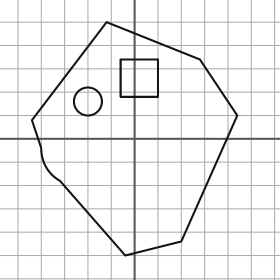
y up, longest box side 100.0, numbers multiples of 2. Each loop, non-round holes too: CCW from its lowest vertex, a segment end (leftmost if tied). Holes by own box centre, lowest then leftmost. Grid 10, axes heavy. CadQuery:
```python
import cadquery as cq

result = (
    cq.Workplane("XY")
    .moveTo(-4.0, -50.0)
    .lineTo(20.0, -44.0)
    .lineTo(44.0, 10.0)
    .lineTo(28.0, 34.0)
    .lineTo(-12.0, 50.0)
    .lineTo(-44.0, 8.0)
    .lineTo(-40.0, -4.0)
    .threePointArc((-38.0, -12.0), (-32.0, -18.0))
    .close()
    .moveTo(-20.0, 16.0)
    .circle(6.0)
    .moveTo(-6.0, 18.0)
    .lineTo(10.0, 18.0)
    .lineTo(10.0, 34.0)
    .lineTo(-6.0, 34.0)
    .close()
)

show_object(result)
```